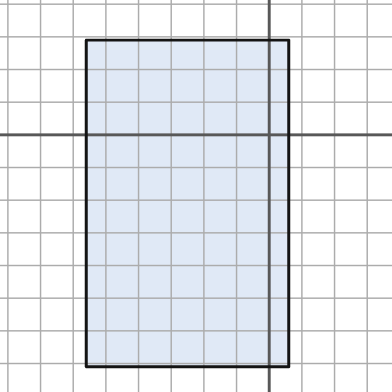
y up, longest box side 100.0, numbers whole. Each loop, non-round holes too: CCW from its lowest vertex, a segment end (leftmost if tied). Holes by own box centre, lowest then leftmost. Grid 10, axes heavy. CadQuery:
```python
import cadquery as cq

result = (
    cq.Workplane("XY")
    .moveTo(-56.0, -71.0)
    .lineTo(6.0, -71.0)
    .lineTo(6.0, 29.0)
    .lineTo(-56.0, 29.0)
    .close()
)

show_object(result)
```